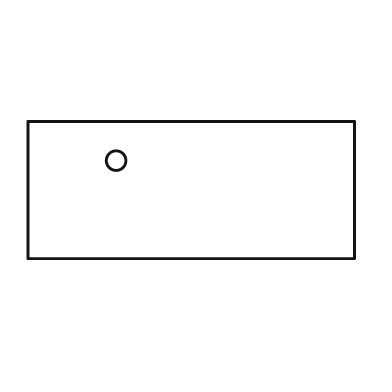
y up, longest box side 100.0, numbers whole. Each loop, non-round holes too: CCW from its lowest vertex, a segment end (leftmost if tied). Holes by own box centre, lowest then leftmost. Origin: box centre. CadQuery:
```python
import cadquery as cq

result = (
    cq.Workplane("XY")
    .moveTo(-50.0, -21.0)
    .lineTo(50.0, -21.0)
    .lineTo(50.0, 21.0)
    .lineTo(-50.0, 21.0)
    .close()
    .moveTo(-23.0, 9.0)
    .circle(3.0)
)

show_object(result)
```